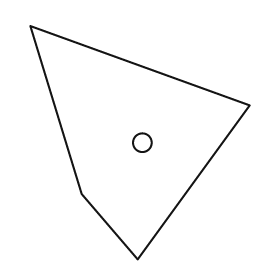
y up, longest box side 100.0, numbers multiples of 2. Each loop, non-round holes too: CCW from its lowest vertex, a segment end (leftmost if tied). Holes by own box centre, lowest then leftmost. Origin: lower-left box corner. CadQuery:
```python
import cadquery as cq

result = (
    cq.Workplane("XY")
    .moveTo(46.0, 0.0)
    .lineTo(94.0, 66.0)
    .lineTo(0.0, 100.0)
    .lineTo(22.0, 28.0)
    .close()
    .moveTo(48.0, 50.0)
    .circle(4.0)
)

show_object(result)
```